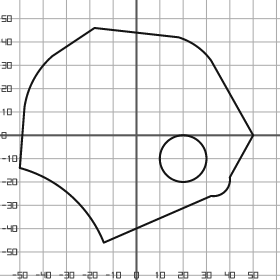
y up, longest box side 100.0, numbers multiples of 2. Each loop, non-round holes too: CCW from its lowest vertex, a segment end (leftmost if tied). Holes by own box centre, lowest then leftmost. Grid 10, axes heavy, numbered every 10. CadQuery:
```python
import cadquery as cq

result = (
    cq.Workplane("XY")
    .moveTo(-14.0, -46.0)
    .lineTo(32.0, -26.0)
    .threePointArc((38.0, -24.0), (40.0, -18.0))
    .lineTo(50.0, 0.0)
    .lineTo(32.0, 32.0)
    .threePointArc((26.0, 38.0), (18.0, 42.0))
    .lineTo(-18.0, 46.0)
    .lineTo(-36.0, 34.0)
    .threePointArc((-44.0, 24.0), (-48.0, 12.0))
    .lineTo(-50.0, -14.0)
    .threePointArc((-28.0, -26.0), (-14.0, -46.0))
    .close()
    .moveTo(20.0, -10.0)
    .circle(10.0)
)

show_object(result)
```